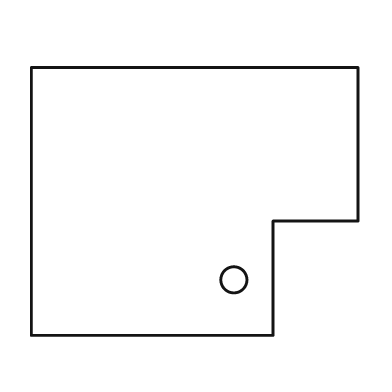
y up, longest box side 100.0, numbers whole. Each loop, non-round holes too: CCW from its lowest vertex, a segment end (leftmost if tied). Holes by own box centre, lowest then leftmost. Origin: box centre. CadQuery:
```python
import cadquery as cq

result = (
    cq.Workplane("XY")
    .moveTo(-50.0, -41.0)
    .lineTo(24.0, -41.0)
    .lineTo(24.0, -6.0)
    .lineTo(50.0, -6.0)
    .lineTo(50.0, 41.0)
    .lineTo(-50.0, 41.0)
    .close()
    .moveTo(12.0, -24.0)
    .circle(4.0)
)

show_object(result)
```